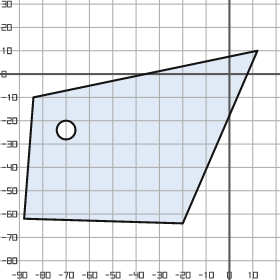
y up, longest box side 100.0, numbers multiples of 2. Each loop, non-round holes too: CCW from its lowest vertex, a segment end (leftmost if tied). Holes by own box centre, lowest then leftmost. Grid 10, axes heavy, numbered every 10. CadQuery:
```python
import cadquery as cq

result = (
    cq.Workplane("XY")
    .moveTo(-20.0, -64.0)
    .lineTo(12.0, 10.0)
    .lineTo(-84.0, -10.0)
    .lineTo(-88.0, -62.0)
    .close()
    .moveTo(-70.0, -24.0)
    .circle(4.0)
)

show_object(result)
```